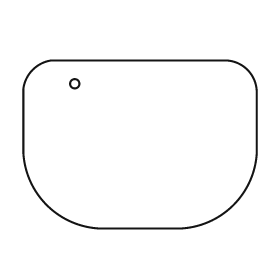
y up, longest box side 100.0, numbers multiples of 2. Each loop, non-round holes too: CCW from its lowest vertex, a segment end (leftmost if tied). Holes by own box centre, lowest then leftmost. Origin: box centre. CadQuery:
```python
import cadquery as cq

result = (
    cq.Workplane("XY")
    .moveTo(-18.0, -36.0)
    .lineTo(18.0, -36.0)
    .threePointArc((40.0, -26.0), (50.0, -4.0))
    .lineTo(50.0, 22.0)
    .threePointArc((46.0, 32.0), (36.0, 36.0))
    .lineTo(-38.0, 36.0)
    .threePointArc((-46.0, 32.0), (-50.0, 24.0))
    .lineTo(-50.0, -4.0)
    .threePointArc((-40.0, -26.0), (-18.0, -36.0))
    .close()
    .moveTo(-28.0, 26.0)
    .circle(2.0)
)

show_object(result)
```